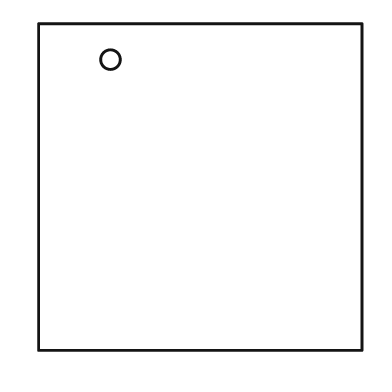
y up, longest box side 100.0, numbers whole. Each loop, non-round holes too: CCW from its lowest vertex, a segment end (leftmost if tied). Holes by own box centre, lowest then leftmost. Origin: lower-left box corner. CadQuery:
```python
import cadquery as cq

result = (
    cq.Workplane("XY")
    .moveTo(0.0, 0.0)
    .lineTo(99.0, 0.0)
    .lineTo(99.0, 100.0)
    .lineTo(0.0, 100.0)
    .close()
    .moveTo(22.0, 89.0)
    .circle(3.0)
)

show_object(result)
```